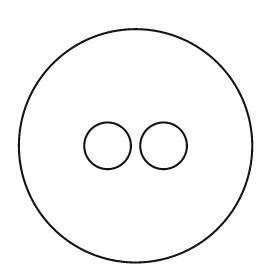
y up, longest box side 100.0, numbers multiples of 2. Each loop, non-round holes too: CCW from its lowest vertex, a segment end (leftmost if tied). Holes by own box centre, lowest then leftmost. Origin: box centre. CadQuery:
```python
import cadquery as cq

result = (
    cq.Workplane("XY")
    .moveTo(0.0, 0.0)
    .circle(50.0)
    .moveTo(-12.0, 0.0)
    .circle(10.0)
    .moveTo(12.0, 0.0)
    .circle(10.0)
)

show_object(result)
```